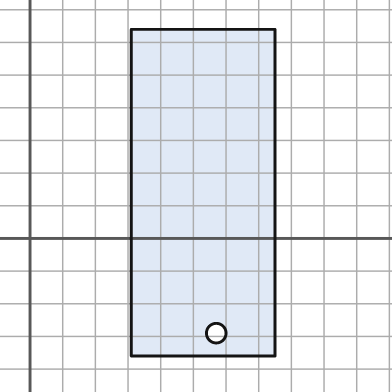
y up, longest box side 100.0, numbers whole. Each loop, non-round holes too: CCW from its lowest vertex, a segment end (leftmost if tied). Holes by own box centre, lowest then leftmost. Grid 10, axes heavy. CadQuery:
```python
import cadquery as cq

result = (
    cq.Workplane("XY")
    .moveTo(31.0, -36.0)
    .lineTo(75.0, -36.0)
    .lineTo(75.0, 64.0)
    .lineTo(31.0, 64.0)
    .close()
    .moveTo(57.0, -29.0)
    .circle(3.0)
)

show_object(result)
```